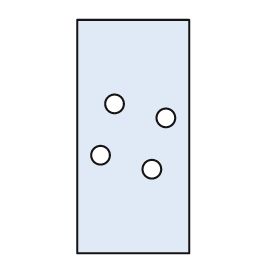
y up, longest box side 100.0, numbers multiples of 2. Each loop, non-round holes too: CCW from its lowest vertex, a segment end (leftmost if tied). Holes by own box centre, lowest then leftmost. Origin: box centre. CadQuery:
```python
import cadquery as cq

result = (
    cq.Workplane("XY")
    .moveTo(-24.0, -50.0)
    .lineTo(24.0, -50.0)
    .lineTo(24.0, 50.0)
    .lineTo(-24.0, 50.0)
    .close()
    .moveTo(8.0, -14.0)
    .circle(4.0)
    .moveTo(-14.0, -8.0)
    .circle(4.0)
    .moveTo(14.0, 8.0)
    .circle(4.0)
    .moveTo(-8.0, 14.0)
    .circle(4.0)
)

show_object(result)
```